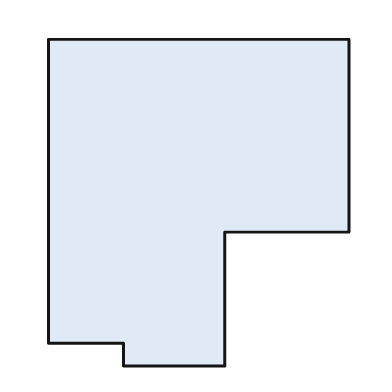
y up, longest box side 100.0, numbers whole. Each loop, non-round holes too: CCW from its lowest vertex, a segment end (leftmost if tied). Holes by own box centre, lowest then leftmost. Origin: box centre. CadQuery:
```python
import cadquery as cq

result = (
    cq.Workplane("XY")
    .moveTo(-23.0, -50.0)
    .lineTo(8.0, -50.0)
    .lineTo(8.0, -9.0)
    .lineTo(46.0, -9.0)
    .lineTo(46.0, 50.0)
    .lineTo(-46.0, 50.0)
    .lineTo(-46.0, -43.0)
    .lineTo(-23.0, -43.0)
    .close()
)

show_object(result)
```